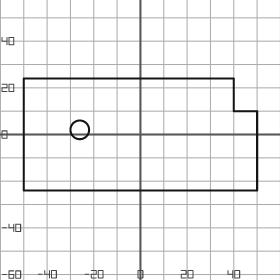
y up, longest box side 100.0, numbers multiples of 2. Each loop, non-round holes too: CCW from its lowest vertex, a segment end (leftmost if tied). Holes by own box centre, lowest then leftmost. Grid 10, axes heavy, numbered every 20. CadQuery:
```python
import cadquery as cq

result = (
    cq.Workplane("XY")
    .moveTo(-50.0, -24.0)
    .lineTo(50.0, -24.0)
    .lineTo(50.0, 10.0)
    .lineTo(40.0, 10.0)
    .lineTo(40.0, 24.0)
    .lineTo(-50.0, 24.0)
    .close()
    .moveTo(-26.0, 2.0)
    .circle(4.0)
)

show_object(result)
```